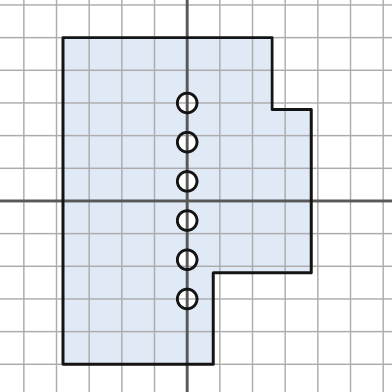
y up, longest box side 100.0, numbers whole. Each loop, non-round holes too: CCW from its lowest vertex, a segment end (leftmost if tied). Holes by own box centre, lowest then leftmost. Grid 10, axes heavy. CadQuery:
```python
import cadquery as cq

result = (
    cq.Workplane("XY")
    .moveTo(-38.0, -50.0)
    .lineTo(8.0, -50.0)
    .lineTo(8.0, -22.0)
    .lineTo(38.0, -22.0)
    .lineTo(38.0, 28.0)
    .lineTo(26.0, 28.0)
    .lineTo(26.0, 50.0)
    .lineTo(-38.0, 50.0)
    .close()
    .moveTo(0.0, -30.0)
    .circle(3.0)
    .moveTo(0.0, -18.0)
    .circle(3.0)
    .moveTo(0.0, -6.0)
    .circle(3.0)
    .moveTo(0.0, 6.0)
    .circle(3.0)
    .moveTo(0.0, 18.0)
    .circle(3.0)
    .moveTo(0.0, 30.0)
    .circle(3.0)
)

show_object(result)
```